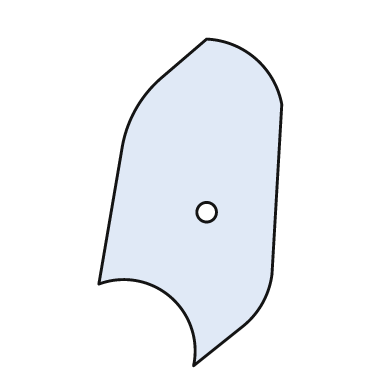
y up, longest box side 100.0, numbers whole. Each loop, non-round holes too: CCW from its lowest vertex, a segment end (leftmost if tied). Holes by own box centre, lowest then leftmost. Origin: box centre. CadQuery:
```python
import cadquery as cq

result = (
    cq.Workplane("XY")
    .moveTo(1.0, -50.0)
    .lineTo(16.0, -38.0)
    .threePointArc((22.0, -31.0), (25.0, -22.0))
    .lineTo(28.0, 30.0)
    .threePointArc((20.0, 44.0), (5.0, 50.0))
    .lineTo(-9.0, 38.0)
    .threePointArc((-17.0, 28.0), (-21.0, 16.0))
    .lineTo(-28.0, -25.0)
    .threePointArc((-6.0, -29.0), (1.0, -50.0))
    .close()
    .moveTo(5.0, -3.0)
    .circle(3.0)
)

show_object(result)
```